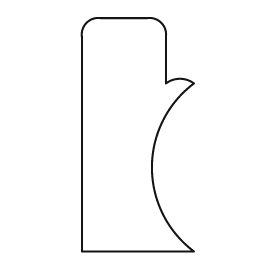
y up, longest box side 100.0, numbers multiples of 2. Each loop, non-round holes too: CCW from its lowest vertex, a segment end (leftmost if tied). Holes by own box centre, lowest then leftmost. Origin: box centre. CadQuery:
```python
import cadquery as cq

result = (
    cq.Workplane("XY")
    .moveTo(-24.0, -50.0)
    .lineTo(24.0, -50.0)
    .threePointArc((6.0, -14.0), (24.0, 22.0))
    .threePointArc((18.0, 24.0), (12.0, 22.0))
    .lineTo(12.0, 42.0)
    .threePointArc((10.0, 48.0), (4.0, 50.0))
    .lineTo(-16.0, 50.0)
    .threePointArc((-22.0, 48.0), (-24.0, 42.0))
    .close()
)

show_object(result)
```